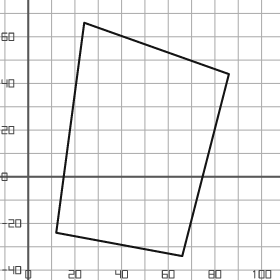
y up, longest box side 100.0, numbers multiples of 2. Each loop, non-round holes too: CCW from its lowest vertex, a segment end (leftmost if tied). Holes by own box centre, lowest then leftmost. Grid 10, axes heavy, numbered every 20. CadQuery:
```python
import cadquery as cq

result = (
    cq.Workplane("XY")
    .moveTo(66.0, -34.0)
    .lineTo(86.0, 44.0)
    .lineTo(24.0, 66.0)
    .lineTo(12.0, -24.0)
    .close()
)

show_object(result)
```